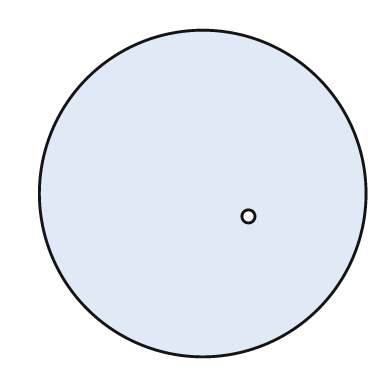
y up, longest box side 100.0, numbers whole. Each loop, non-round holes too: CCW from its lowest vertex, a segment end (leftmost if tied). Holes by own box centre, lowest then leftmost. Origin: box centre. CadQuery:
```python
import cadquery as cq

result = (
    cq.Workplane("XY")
    .moveTo(0.0, 0.0)
    .circle(50.0)
    .moveTo(14.0, -7.0)
    .circle(2.0)
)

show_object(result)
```